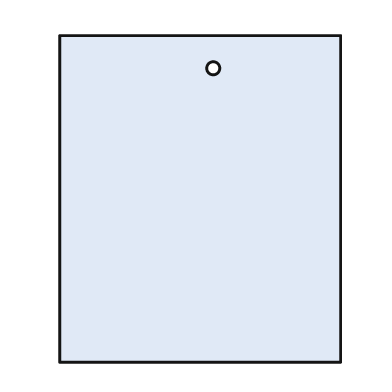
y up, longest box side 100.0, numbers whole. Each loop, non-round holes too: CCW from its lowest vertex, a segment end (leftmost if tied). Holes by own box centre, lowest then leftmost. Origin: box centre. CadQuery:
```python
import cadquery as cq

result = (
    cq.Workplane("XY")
    .moveTo(-43.0, -50.0)
    .lineTo(43.0, -50.0)
    .lineTo(43.0, 50.0)
    .lineTo(-43.0, 50.0)
    .close()
    .moveTo(4.0, 40.0)
    .circle(2.0)
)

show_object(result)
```